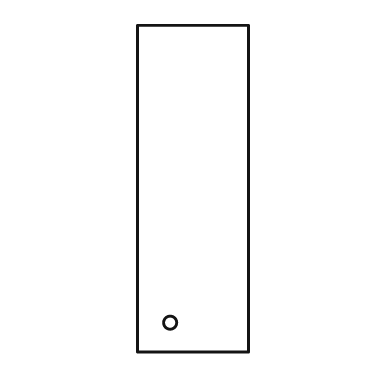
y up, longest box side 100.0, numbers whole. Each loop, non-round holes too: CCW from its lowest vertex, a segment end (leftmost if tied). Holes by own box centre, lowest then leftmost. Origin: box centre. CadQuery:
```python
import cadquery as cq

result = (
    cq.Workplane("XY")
    .moveTo(-17.0, -50.0)
    .lineTo(17.0, -50.0)
    .lineTo(17.0, 50.0)
    .lineTo(-17.0, 50.0)
    .close()
    .moveTo(-7.0, -41.0)
    .circle(2.0)
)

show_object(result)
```